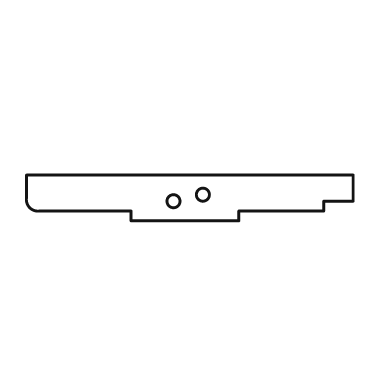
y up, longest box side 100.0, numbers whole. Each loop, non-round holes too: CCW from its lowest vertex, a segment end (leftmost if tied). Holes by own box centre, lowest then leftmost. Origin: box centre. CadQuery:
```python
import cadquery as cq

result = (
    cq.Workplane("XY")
    .moveTo(-18.0, -7.0)
    .lineTo(15.0, -7.0)
    .lineTo(15.0, -4.0)
    .lineTo(41.0, -4.0)
    .lineTo(41.0, -1.0)
    .lineTo(50.0, -1.0)
    .lineTo(50.0, 7.0)
    .lineTo(-50.0, 7.0)
    .lineTo(-50.0, 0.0)
    .threePointArc((-49.0, -3.0), (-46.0, -4.0))
    .lineTo(-18.0, -4.0)
    .close()
    .moveTo(-5.0, -1.0)
    .circle(2.0)
    .moveTo(4.0, 1.0)
    .circle(2.0)
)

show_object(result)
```